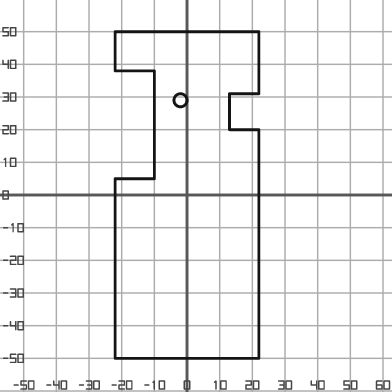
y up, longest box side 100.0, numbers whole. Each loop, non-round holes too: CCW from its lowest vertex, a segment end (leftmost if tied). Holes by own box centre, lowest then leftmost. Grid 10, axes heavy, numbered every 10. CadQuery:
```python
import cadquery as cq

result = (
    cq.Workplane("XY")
    .moveTo(-22.0, -50.0)
    .lineTo(22.0, -50.0)
    .lineTo(22.0, 20.0)
    .lineTo(13.0, 20.0)
    .lineTo(13.0, 31.0)
    .lineTo(22.0, 31.0)
    .lineTo(22.0, 50.0)
    .lineTo(-22.0, 50.0)
    .lineTo(-22.0, 38.0)
    .lineTo(-10.0, 38.0)
    .lineTo(-10.0, 5.0)
    .lineTo(-22.0, 5.0)
    .close()
    .moveTo(-2.0, 29.0)
    .circle(2.0)
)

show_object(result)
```